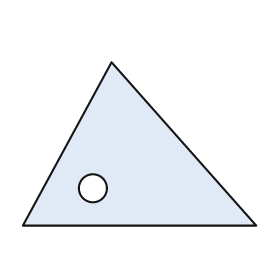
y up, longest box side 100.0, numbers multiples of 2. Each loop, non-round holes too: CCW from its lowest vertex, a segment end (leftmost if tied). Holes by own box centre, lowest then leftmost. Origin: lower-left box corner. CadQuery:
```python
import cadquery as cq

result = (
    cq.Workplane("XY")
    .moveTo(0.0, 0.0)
    .lineTo(100.0, 0.0)
    .lineTo(38.0, 70.0)
    .close()
    .moveTo(30.0, 16.0)
    .circle(6.0)
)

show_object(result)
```